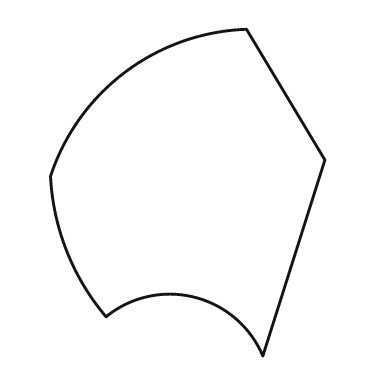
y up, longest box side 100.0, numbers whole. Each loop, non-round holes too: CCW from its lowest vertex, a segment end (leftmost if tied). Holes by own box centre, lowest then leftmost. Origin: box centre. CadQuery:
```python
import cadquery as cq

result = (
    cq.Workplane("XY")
    .moveTo(23.0, -50.0)
    .lineTo(42.0, 10.0)
    .lineTo(18.0, 50.0)
    .threePointArc((-19.0, 37.0), (-42.0, 5.0))
    .threePointArc((-37.0, -18.0), (-25.0, -38.0))
    .threePointArc((2.0, -32.0), (23.0, -50.0))
    .close()
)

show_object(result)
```